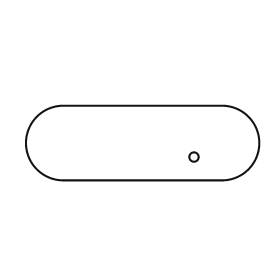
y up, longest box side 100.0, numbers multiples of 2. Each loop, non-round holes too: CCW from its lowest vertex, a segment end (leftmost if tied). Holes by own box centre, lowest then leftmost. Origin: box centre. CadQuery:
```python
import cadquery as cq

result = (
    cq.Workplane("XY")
    .moveTo(-34.0, -16.0)
    .lineTo(34.0, -16.0)
    .threePointArc((50.0, 0.0), (34.0, 16.0))
    .lineTo(-34.0, 16.0)
    .threePointArc((-50.0, 0.0), (-34.0, -16.0))
    .close()
    .moveTo(22.0, -6.0)
    .circle(2.0)
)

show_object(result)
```